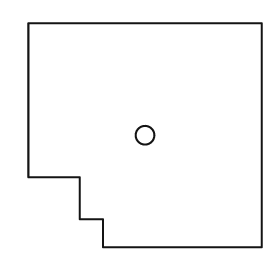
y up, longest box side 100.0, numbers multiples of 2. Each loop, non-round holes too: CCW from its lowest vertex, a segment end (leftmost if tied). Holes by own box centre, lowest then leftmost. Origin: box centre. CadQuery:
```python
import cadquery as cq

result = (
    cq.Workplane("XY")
    .moveTo(-18.0, -48.0)
    .lineTo(50.0, -48.0)
    .lineTo(50.0, 48.0)
    .lineTo(-50.0, 48.0)
    .lineTo(-50.0, -18.0)
    .lineTo(-28.0, -18.0)
    .lineTo(-28.0, -36.0)
    .lineTo(-18.0, -36.0)
    .close()
    .moveTo(0.0, 0.0)
    .circle(4.0)
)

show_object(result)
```